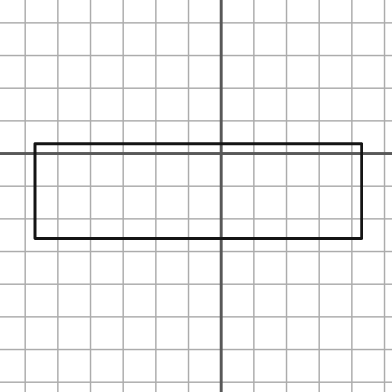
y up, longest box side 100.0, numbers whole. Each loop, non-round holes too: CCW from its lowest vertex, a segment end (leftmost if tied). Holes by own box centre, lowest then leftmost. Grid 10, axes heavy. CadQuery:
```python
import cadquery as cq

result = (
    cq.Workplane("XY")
    .moveTo(-57.0, -26.0)
    .lineTo(43.0, -26.0)
    .lineTo(43.0, 3.0)
    .lineTo(-57.0, 3.0)
    .close()
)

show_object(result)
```